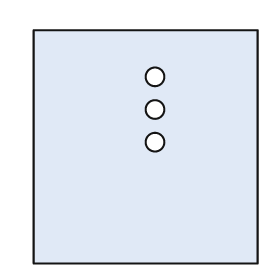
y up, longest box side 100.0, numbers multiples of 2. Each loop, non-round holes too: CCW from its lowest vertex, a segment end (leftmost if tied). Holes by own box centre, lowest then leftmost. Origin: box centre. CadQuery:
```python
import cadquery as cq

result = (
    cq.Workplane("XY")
    .moveTo(-48.0, -50.0)
    .lineTo(48.0, -50.0)
    .lineTo(48.0, 50.0)
    .lineTo(-48.0, 50.0)
    .close()
    .moveTo(4.0, 2.0)
    .circle(4.0)
    .moveTo(4.0, 16.0)
    .circle(4.0)
    .moveTo(4.0, 30.0)
    .circle(4.0)
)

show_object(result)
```